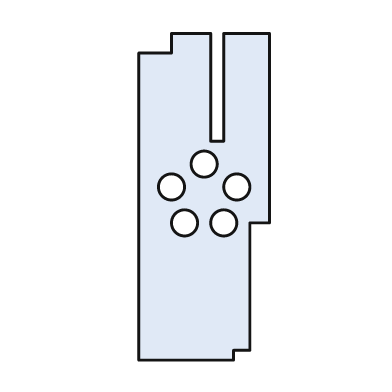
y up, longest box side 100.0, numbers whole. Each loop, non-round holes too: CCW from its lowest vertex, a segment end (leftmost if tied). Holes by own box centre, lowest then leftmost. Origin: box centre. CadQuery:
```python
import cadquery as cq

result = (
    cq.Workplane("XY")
    .moveTo(-20.0, -50.0)
    .lineTo(9.0, -50.0)
    .lineTo(9.0, -47.0)
    .lineTo(14.0, -47.0)
    .lineTo(14.0, -8.0)
    .lineTo(20.0, -8.0)
    .lineTo(20.0, 50.0)
    .lineTo(6.0, 50.0)
    .lineTo(6.0, 17.0)
    .lineTo(2.0, 17.0)
    .lineTo(2.0, 50.0)
    .lineTo(-10.0, 50.0)
    .lineTo(-10.0, 44.0)
    .lineTo(-20.0, 44.0)
    .close()
    .moveTo(-6.0, -8.0)
    .circle(4.0)
    .moveTo(6.0, -8.0)
    .circle(4.0)
    .moveTo(-10.0, 3.0)
    .circle(4.0)
    .moveTo(10.0, 3.0)
    .circle(4.0)
    .moveTo(0.0, 10.0)
    .circle(4.0)
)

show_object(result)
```